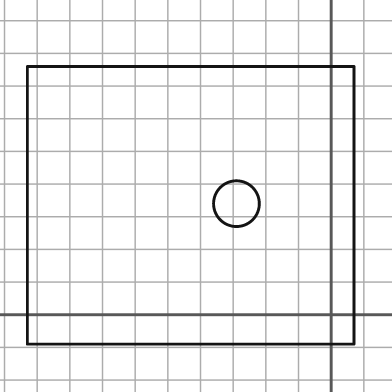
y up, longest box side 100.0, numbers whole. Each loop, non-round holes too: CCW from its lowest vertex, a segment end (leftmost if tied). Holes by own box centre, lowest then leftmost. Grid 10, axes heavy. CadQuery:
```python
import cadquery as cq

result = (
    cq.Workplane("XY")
    .moveTo(-93.0, -9.0)
    .lineTo(7.0, -9.0)
    .lineTo(7.0, 76.0)
    .lineTo(-93.0, 76.0)
    .close()
    .moveTo(-29.0, 34.0)
    .circle(7.0)
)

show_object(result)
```